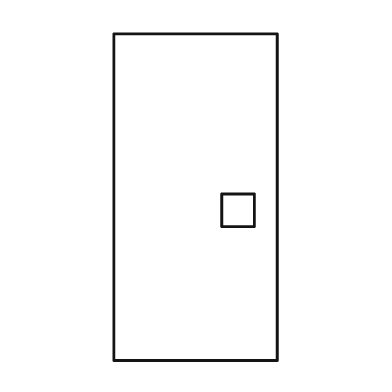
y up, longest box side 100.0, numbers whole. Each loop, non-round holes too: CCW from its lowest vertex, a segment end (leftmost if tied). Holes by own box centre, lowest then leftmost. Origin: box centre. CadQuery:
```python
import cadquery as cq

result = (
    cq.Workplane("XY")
    .moveTo(-25.0, -50.0)
    .lineTo(25.0, -50.0)
    .lineTo(25.0, 50.0)
    .lineTo(-25.0, 50.0)
    .close()
    .moveTo(8.0, -9.0)
    .lineTo(18.0, -9.0)
    .lineTo(18.0, 1.0)
    .lineTo(8.0, 1.0)
    .close()
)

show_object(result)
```